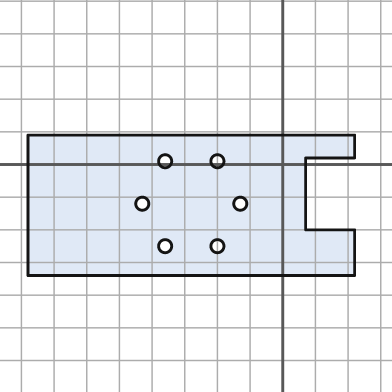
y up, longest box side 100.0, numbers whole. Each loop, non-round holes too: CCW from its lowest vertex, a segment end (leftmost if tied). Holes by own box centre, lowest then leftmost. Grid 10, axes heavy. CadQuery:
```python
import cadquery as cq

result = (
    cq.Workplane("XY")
    .moveTo(-78.0, -34.0)
    .lineTo(22.0, -34.0)
    .lineTo(22.0, -20.0)
    .lineTo(7.0, -20.0)
    .lineTo(7.0, 2.0)
    .lineTo(22.0, 2.0)
    .lineTo(22.0, 9.0)
    .lineTo(-78.0, 9.0)
    .close()
    .moveTo(-36.0, -25.0)
    .circle(2.0)
    .moveTo(-20.0, -25.0)
    .circle(2.0)
    .moveTo(-43.0, -12.0)
    .circle(2.0)
    .moveTo(-13.0, -12.0)
    .circle(2.0)
    .moveTo(-36.0, 1.0)
    .circle(2.0)
    .moveTo(-20.0, 1.0)
    .circle(2.0)
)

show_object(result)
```